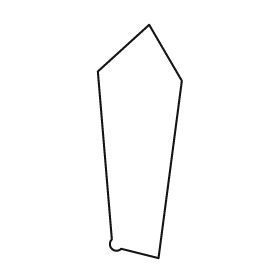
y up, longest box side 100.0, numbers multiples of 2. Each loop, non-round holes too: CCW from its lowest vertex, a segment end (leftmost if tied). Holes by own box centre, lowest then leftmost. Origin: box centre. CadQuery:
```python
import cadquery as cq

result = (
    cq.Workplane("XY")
    .moveTo(8.0, -50.0)
    .lineTo(18.0, 26.0)
    .lineTo(4.0, 50.0)
    .lineTo(-18.0, 30.0)
    .lineTo(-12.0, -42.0)
    .threePointArc((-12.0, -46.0), (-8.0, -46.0))
    .close()
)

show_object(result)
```